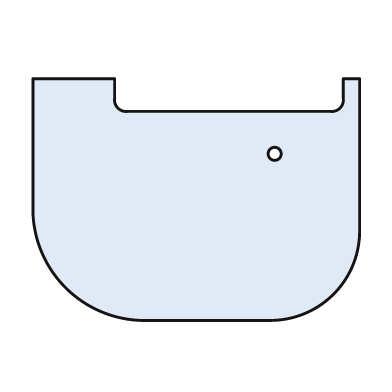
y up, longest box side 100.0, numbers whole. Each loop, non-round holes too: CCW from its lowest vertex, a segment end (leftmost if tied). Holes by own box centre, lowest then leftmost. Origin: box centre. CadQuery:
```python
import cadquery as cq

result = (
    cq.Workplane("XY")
    .moveTo(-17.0, -37.0)
    .lineTo(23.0, -37.0)
    .threePointArc((42.0, -29.0), (50.0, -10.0))
    .lineTo(50.0, 37.0)
    .lineTo(45.0, 37.0)
    .lineTo(45.0, 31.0)
    .threePointArc((44.0, 28.0), (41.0, 27.0))
    .lineTo(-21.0, 27.0)
    .threePointArc((-24.0, 28.0), (-25.0, 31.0))
    .lineTo(-25.0, 37.0)
    .lineTo(-50.0, 37.0)
    .lineTo(-50.0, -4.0)
    .threePointArc((-40.0, -27.0), (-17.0, -37.0))
    .close()
    .moveTo(24.0, 14.0)
    .circle(2.0)
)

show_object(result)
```